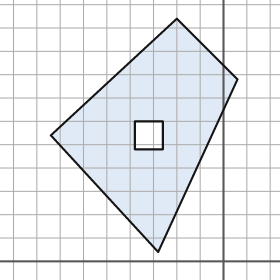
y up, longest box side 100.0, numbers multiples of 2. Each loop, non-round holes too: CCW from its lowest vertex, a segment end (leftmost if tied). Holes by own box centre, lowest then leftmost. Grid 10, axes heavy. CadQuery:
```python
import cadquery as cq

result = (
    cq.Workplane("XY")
    .moveTo(-28.0, 4.0)
    .lineTo(6.0, 78.0)
    .lineTo(-20.0, 104.0)
    .lineTo(-74.0, 54.0)
    .close()
    .moveTo(-38.0, 48.0)
    .lineTo(-26.0, 48.0)
    .lineTo(-26.0, 60.0)
    .lineTo(-38.0, 60.0)
    .close()
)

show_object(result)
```